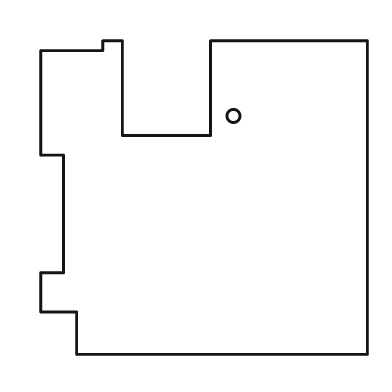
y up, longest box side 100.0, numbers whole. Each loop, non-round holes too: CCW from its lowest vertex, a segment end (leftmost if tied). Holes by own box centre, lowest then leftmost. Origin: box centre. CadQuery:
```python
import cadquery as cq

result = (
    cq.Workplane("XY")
    .moveTo(-39.0, -48.0)
    .lineTo(50.0, -48.0)
    .lineTo(50.0, 48.0)
    .lineTo(2.0, 48.0)
    .lineTo(2.0, 19.0)
    .lineTo(-25.0, 19.0)
    .lineTo(-25.0, 48.0)
    .lineTo(-31.0, 48.0)
    .lineTo(-31.0, 45.0)
    .lineTo(-50.0, 45.0)
    .lineTo(-50.0, 13.0)
    .lineTo(-43.0, 13.0)
    .lineTo(-43.0, -23.0)
    .lineTo(-50.0, -23.0)
    .lineTo(-50.0, -35.0)
    .lineTo(-39.0, -35.0)
    .close()
    .moveTo(9.0, 25.0)
    .circle(2.0)
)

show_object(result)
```